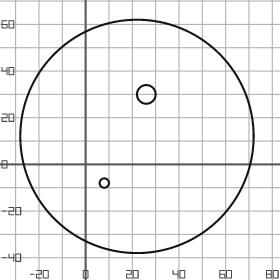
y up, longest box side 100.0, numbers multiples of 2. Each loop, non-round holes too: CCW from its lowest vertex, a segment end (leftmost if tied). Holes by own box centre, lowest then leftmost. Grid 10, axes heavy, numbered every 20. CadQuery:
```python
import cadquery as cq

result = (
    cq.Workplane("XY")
    .moveTo(22.0, 12.0)
    .circle(50.0)
    .moveTo(8.0, -8.0)
    .circle(2.0)
    .moveTo(26.0, 30.0)
    .circle(4.0)
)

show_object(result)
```